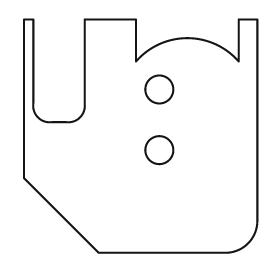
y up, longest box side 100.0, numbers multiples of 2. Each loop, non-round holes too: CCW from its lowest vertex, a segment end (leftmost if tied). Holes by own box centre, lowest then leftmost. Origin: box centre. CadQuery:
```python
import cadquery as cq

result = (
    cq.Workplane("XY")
    .moveTo(-18.0, -50.0)
    .lineTo(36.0, -50.0)
    .threePointArc((46.0, -46.0), (50.0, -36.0))
    .lineTo(50.0, 50.0)
    .lineTo(42.0, 50.0)
    .lineTo(42.0, 32.0)
    .threePointArc((20.0, 42.0), (-2.0, 32.0))
    .lineTo(-2.0, 50.0)
    .lineTo(-24.0, 50.0)
    .lineTo(-24.0, 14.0)
    .threePointArc((-26.0, 8.0), (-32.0, 6.0))
    .lineTo(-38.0, 6.0)
    .threePointArc((-44.0, 8.0), (-46.0, 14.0))
    .lineTo(-46.0, 50.0)
    .lineTo(-50.0, 50.0)
    .lineTo(-50.0, -18.0)
    .close()
    .moveTo(8.0, -6.0)
    .circle(6.0)
    .moveTo(8.0, 20.0)
    .circle(6.0)
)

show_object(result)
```